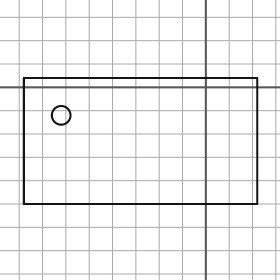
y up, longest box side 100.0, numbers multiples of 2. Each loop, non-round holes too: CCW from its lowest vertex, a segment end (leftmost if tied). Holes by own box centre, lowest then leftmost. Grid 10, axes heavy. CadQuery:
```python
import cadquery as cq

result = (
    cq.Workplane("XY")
    .moveTo(-78.0, -50.0)
    .lineTo(22.0, -50.0)
    .lineTo(22.0, 4.0)
    .lineTo(-78.0, 4.0)
    .close()
    .moveTo(-62.0, -12.0)
    .circle(4.0)
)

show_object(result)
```